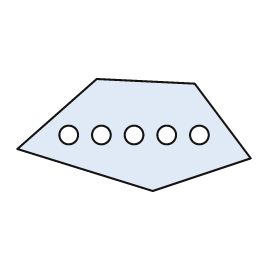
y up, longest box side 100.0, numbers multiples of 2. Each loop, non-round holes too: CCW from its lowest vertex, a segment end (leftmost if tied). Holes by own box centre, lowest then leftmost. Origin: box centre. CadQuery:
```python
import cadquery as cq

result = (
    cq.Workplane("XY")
    .moveTo(8.0, -24.0)
    .lineTo(50.0, -10.0)
    .lineTo(26.0, 22.0)
    .lineTo(-16.0, 24.0)
    .lineTo(-50.0, -6.0)
    .close()
    .moveTo(-28.0, 0.0)
    .circle(4.0)
    .moveTo(-14.0, 0.0)
    .circle(4.0)
    .moveTo(0.0, 0.0)
    .circle(4.0)
    .moveTo(14.0, 0.0)
    .circle(4.0)
    .moveTo(28.0, 0.0)
    .circle(4.0)
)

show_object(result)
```